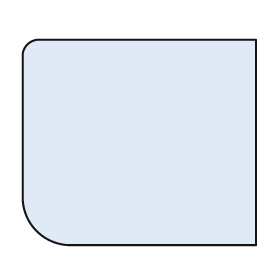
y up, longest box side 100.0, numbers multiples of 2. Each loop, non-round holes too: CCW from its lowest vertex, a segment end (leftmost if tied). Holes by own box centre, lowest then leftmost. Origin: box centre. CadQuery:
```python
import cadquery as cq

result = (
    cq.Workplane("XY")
    .moveTo(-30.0, -44.0)
    .lineTo(50.0, -44.0)
    .lineTo(50.0, 44.0)
    .lineTo(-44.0, 44.0)
    .threePointArc((-48.0, 42.0), (-50.0, 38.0))
    .lineTo(-50.0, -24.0)
    .threePointArc((-44.0, -38.0), (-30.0, -44.0))
    .close()
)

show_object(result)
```